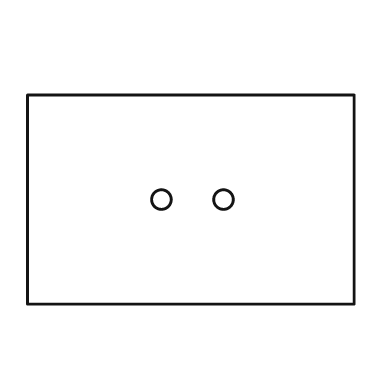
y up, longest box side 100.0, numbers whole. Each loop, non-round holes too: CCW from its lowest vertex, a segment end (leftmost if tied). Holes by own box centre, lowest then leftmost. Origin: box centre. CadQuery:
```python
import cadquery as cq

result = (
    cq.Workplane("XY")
    .moveTo(-50.0, -32.0)
    .lineTo(50.0, -32.0)
    .lineTo(50.0, 32.0)
    .lineTo(-50.0, 32.0)
    .close()
    .moveTo(-9.0, 0.0)
    .circle(3.0)
    .moveTo(10.0, 0.0)
    .circle(3.0)
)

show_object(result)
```